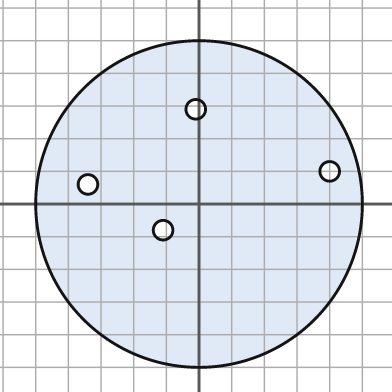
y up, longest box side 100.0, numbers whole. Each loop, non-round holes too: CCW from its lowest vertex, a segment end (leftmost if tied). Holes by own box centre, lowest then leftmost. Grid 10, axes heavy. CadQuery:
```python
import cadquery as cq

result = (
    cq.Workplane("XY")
    .moveTo(0.0, 0.0)
    .circle(50.0)
    .moveTo(-11.0, -8.0)
    .circle(3.0)
    .moveTo(-34.0, 6.0)
    .circle(3.0)
    .moveTo(40.0, 10.0)
    .circle(3.0)
    .moveTo(-1.0, 29.0)
    .circle(3.0)
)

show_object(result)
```